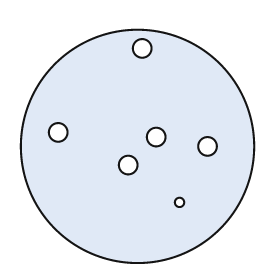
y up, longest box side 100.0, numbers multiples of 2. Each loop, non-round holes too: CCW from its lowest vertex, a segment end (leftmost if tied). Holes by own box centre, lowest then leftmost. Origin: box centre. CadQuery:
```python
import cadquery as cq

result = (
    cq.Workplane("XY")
    .moveTo(0.0, 0.0)
    .circle(50.0)
    .moveTo(18.0, -24.0)
    .circle(2.0)
    .moveTo(-4.0, -8.0)
    .circle(4.0)
    .moveTo(30.0, 0.0)
    .circle(4.0)
    .moveTo(8.0, 4.0)
    .circle(4.0)
    .moveTo(-34.0, 6.0)
    .circle(4.0)
    .moveTo(2.0, 42.0)
    .circle(4.0)
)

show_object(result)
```